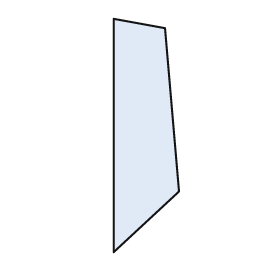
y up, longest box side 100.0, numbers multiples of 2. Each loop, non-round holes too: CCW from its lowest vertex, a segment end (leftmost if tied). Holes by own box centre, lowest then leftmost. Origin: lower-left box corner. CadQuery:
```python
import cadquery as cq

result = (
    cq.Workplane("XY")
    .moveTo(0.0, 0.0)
    .lineTo(28.0, 26.0)
    .lineTo(22.0, 96.0)
    .lineTo(0.0, 100.0)
    .close()
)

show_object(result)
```